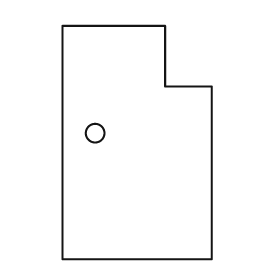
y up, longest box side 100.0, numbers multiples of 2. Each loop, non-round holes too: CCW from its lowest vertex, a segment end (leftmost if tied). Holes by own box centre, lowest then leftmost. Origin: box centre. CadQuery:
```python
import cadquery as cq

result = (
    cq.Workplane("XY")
    .moveTo(-32.0, -50.0)
    .lineTo(32.0, -50.0)
    .lineTo(32.0, 24.0)
    .lineTo(12.0, 24.0)
    .lineTo(12.0, 50.0)
    .lineTo(-32.0, 50.0)
    .close()
    .moveTo(-18.0, 4.0)
    .circle(4.0)
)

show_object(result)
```